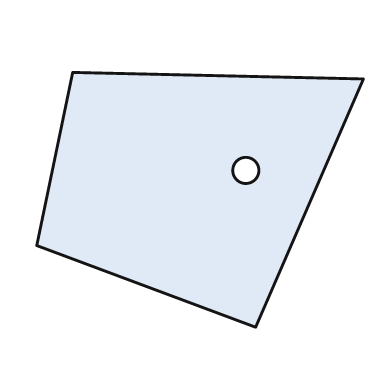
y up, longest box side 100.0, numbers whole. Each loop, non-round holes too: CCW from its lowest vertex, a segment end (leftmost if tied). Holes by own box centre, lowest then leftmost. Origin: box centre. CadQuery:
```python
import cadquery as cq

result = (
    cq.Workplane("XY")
    .moveTo(17.0, -39.0)
    .lineTo(50.0, 37.0)
    .lineTo(-39.0, 39.0)
    .lineTo(-50.0, -14.0)
    .close()
    .moveTo(14.0, 9.0)
    .circle(4.0)
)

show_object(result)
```